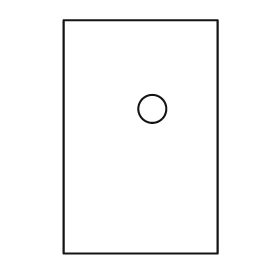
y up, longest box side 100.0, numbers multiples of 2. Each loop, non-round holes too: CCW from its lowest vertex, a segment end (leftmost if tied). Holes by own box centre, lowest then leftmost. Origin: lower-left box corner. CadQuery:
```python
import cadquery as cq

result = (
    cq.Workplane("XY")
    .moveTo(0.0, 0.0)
    .lineTo(66.0, 0.0)
    .lineTo(66.0, 100.0)
    .lineTo(0.0, 100.0)
    .close()
    .moveTo(38.0, 62.0)
    .circle(6.0)
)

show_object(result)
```